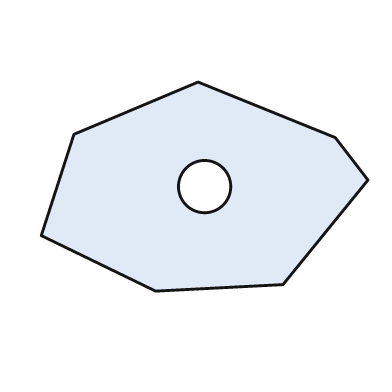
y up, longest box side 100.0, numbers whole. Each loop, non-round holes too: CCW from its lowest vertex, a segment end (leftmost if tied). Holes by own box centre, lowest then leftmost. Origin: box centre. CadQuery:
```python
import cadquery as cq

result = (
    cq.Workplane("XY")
    .moveTo(-15.0, -32.0)
    .lineTo(24.0, -30.0)
    .lineTo(50.0, 2.0)
    .lineTo(40.0, 15.0)
    .lineTo(-2.0, 32.0)
    .lineTo(-40.0, 16.0)
    .lineTo(-50.0, -15.0)
    .close()
    .moveTo(0.0, 0.0)
    .circle(8.0)
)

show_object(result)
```